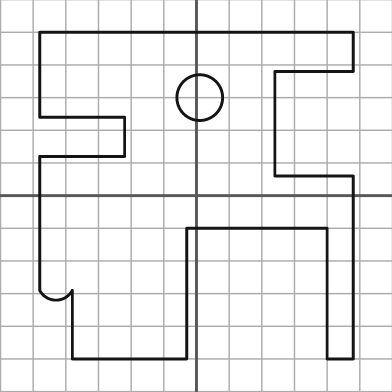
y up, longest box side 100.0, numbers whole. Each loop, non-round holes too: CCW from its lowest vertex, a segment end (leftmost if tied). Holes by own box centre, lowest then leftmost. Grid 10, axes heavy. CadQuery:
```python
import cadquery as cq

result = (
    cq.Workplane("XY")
    .moveTo(-38.0, -50.0)
    .lineTo(-3.0, -50.0)
    .lineTo(-3.0, -10.0)
    .lineTo(40.0, -10.0)
    .lineTo(40.0, -50.0)
    .lineTo(48.0, -50.0)
    .lineTo(48.0, 6.0)
    .lineTo(24.0, 6.0)
    .lineTo(24.0, 38.0)
    .lineTo(48.0, 38.0)
    .lineTo(48.0, 50.0)
    .lineTo(-48.0, 50.0)
    .lineTo(-48.0, 24.0)
    .lineTo(-22.0, 24.0)
    .lineTo(-22.0, 12.0)
    .lineTo(-48.0, 12.0)
    .lineTo(-48.0, -29.0)
    .threePointArc((-43.0, -32.0), (-38.0, -29.0))
    .close()
    .moveTo(1.0, 30.0)
    .circle(7.0)
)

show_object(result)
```